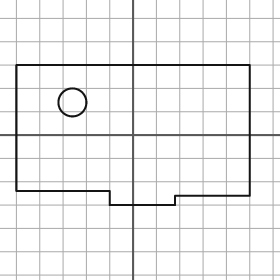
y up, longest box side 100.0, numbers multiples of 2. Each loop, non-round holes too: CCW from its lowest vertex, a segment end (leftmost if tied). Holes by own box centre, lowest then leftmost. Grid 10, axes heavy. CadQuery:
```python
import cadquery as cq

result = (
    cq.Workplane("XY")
    .moveTo(-10.0, -30.0)
    .lineTo(18.0, -30.0)
    .lineTo(18.0, -26.0)
    .lineTo(50.0, -26.0)
    .lineTo(50.0, 30.0)
    .lineTo(-50.0, 30.0)
    .lineTo(-50.0, -24.0)
    .lineTo(-10.0, -24.0)
    .close()
    .moveTo(-26.0, 14.0)
    .circle(6.0)
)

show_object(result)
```